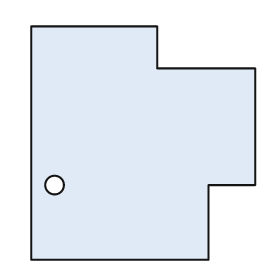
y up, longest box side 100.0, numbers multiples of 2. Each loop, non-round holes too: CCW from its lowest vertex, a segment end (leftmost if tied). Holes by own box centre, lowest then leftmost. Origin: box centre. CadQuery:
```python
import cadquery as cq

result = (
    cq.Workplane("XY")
    .moveTo(-48.0, -50.0)
    .lineTo(28.0, -50.0)
    .lineTo(28.0, -18.0)
    .lineTo(48.0, -18.0)
    .lineTo(48.0, 32.0)
    .lineTo(6.0, 32.0)
    .lineTo(6.0, 50.0)
    .lineTo(-48.0, 50.0)
    .close()
    .moveTo(-38.0, -18.0)
    .circle(4.0)
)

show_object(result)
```